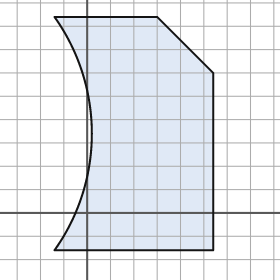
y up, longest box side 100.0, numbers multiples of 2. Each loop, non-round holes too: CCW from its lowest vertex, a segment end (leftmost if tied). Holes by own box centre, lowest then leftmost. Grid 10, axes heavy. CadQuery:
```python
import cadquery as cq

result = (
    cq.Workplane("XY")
    .moveTo(-14.0, -16.0)
    .lineTo(54.0, -16.0)
    .lineTo(54.0, 60.0)
    .lineTo(30.0, 84.0)
    .lineTo(-14.0, 84.0)
    .threePointArc((2.0, 34.0), (-14.0, -16.0))
    .close()
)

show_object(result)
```